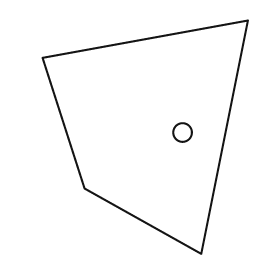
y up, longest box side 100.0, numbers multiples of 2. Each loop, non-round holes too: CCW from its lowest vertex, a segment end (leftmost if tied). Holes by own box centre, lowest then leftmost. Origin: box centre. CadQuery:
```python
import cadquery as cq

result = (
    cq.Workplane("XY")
    .moveTo(24.0, -50.0)
    .lineTo(44.0, 50.0)
    .lineTo(-44.0, 34.0)
    .lineTo(-26.0, -22.0)
    .close()
    .moveTo(16.0, 2.0)
    .circle(4.0)
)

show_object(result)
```